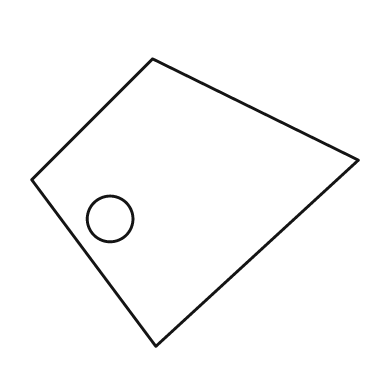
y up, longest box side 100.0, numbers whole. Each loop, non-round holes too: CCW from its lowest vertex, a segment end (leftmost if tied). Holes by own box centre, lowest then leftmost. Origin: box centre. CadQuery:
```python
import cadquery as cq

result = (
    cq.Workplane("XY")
    .moveTo(-12.0, -44.0)
    .lineTo(50.0, 13.0)
    .lineTo(-13.0, 44.0)
    .lineTo(-50.0, 7.0)
    .close()
    .moveTo(-26.0, -5.0)
    .circle(7.0)
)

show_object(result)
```